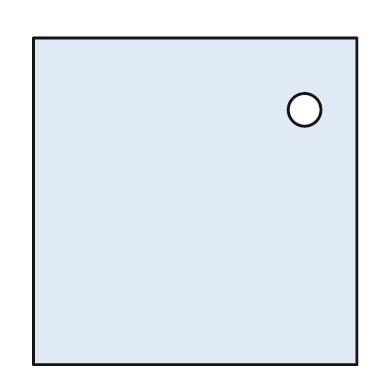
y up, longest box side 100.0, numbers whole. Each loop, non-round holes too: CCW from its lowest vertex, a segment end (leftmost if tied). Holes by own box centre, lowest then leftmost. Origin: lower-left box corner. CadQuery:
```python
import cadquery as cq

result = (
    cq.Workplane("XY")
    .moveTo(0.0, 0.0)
    .lineTo(99.0, 0.0)
    .lineTo(99.0, 100.0)
    .lineTo(0.0, 100.0)
    .close()
    .moveTo(83.0, 78.0)
    .circle(5.0)
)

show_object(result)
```